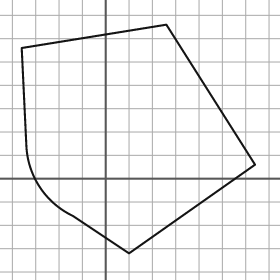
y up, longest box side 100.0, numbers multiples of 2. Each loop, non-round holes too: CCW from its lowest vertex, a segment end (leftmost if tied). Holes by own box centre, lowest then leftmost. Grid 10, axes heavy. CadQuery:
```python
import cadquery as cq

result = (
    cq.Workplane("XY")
    .moveTo(10.0, -32.0)
    .lineTo(64.0, 6.0)
    .lineTo(26.0, 66.0)
    .lineTo(-36.0, 56.0)
    .lineTo(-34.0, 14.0)
    .threePointArc((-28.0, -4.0), (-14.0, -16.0))
    .close()
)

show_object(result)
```